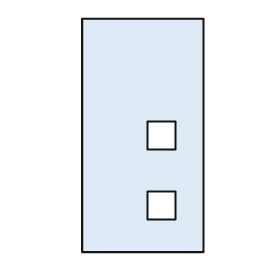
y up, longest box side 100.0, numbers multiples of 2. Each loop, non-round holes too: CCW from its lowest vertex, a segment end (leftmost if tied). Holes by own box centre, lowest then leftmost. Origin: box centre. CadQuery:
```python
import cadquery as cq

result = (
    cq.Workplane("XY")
    .moveTo(-26.0, -50.0)
    .lineTo(26.0, -50.0)
    .lineTo(26.0, 50.0)
    .lineTo(-26.0, 50.0)
    .close()
    .moveTo(2.0, -36.0)
    .lineTo(14.0, -36.0)
    .lineTo(14.0, -24.0)
    .lineTo(2.0, -24.0)
    .close()
    .moveTo(2.0, -6.0)
    .lineTo(14.0, -6.0)
    .lineTo(14.0, 6.0)
    .lineTo(2.0, 6.0)
    .close()
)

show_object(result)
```